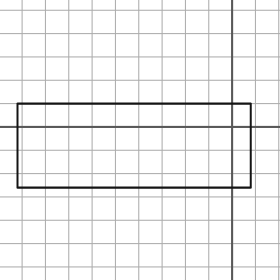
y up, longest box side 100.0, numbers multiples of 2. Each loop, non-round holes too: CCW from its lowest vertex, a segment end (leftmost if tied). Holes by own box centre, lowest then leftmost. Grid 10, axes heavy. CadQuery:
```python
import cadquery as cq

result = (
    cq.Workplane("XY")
    .moveTo(-92.0, -26.0)
    .lineTo(8.0, -26.0)
    .lineTo(8.0, 10.0)
    .lineTo(-92.0, 10.0)
    .close()
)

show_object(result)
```